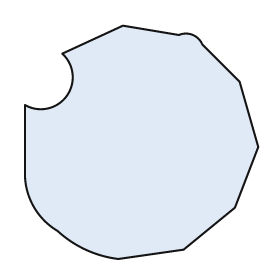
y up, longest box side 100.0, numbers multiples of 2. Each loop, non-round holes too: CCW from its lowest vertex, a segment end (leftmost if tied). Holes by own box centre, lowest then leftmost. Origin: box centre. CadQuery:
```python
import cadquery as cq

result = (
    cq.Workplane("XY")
    .moveTo(-10.0, -50.0)
    .lineTo(18.0, -46.0)
    .lineTo(40.0, -28.0)
    .lineTo(50.0, -2.0)
    .lineTo(42.0, 26.0)
    .lineTo(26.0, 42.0)
    .threePointArc((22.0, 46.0), (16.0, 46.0))
    .lineTo(-8.0, 50.0)
    .lineTo(-34.0, 38.0)
    .threePointArc((-32.0, 20.0), (-50.0, 16.0))
    .lineTo(-50.0, -14.0)
    .threePointArc((-46.0, -28.0), (-36.0, -38.0))
    .threePointArc((-24.0, -46.0), (-10.0, -50.0))
    .close()
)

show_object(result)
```